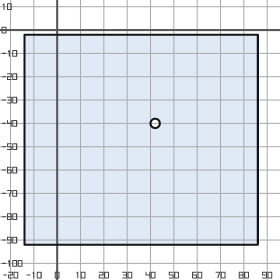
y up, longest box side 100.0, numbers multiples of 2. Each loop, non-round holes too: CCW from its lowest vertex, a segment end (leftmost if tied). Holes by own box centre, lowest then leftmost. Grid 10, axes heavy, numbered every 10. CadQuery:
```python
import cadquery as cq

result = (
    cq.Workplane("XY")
    .moveTo(-14.0, -92.0)
    .lineTo(86.0, -92.0)
    .lineTo(86.0, -2.0)
    .lineTo(-14.0, -2.0)
    .close()
    .moveTo(42.0, -40.0)
    .circle(2.0)
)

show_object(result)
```